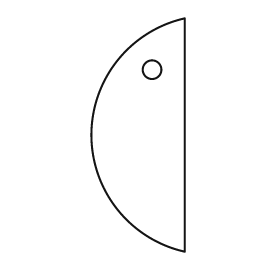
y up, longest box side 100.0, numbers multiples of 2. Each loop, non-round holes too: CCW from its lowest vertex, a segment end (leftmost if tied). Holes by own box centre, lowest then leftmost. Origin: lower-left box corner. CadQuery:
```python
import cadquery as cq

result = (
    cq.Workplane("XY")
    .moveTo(40.0, 0.0)
    .lineTo(40.0, 100.0)
    .threePointArc((0.0, 50.0), (40.0, 0.0))
    .close()
    .moveTo(26.0, 78.0)
    .circle(4.0)
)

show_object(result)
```